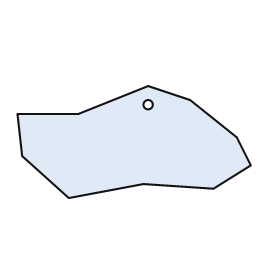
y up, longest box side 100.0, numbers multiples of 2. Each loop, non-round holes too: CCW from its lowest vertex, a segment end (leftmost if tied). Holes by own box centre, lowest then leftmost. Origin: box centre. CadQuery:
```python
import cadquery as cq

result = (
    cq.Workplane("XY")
    .moveTo(-28.0, -24.0)
    .lineTo(4.0, -18.0)
    .lineTo(34.0, -20.0)
    .lineTo(50.0, -10.0)
    .lineTo(44.0, 2.0)
    .lineTo(24.0, 18.0)
    .lineTo(6.0, 24.0)
    .lineTo(-24.0, 12.0)
    .lineTo(-50.0, 12.0)
    .lineTo(-48.0, -6.0)
    .close()
    .moveTo(6.0, 16.0)
    .circle(2.0)
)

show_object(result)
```